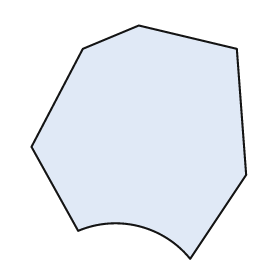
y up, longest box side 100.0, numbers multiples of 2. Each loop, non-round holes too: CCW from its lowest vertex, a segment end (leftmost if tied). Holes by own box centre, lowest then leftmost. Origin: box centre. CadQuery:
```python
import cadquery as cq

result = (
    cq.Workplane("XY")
    .moveTo(22.0, -50.0)
    .lineTo(46.0, -14.0)
    .lineTo(42.0, 40.0)
    .lineTo(0.0, 50.0)
    .lineTo(-24.0, 40.0)
    .lineTo(-46.0, -2.0)
    .lineTo(-26.0, -38.0)
    .threePointArc((0.0, -36.0), (22.0, -50.0))
    .close()
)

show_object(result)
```